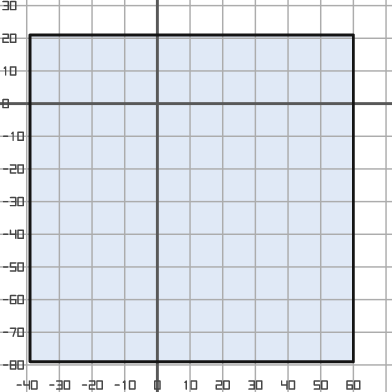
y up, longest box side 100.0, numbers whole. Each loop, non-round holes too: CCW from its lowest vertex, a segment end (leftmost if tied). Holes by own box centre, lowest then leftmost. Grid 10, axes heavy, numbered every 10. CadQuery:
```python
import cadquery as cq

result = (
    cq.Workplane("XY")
    .moveTo(-39.0, -79.0)
    .lineTo(60.0, -79.0)
    .lineTo(60.0, 21.0)
    .lineTo(-39.0, 21.0)
    .close()
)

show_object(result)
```